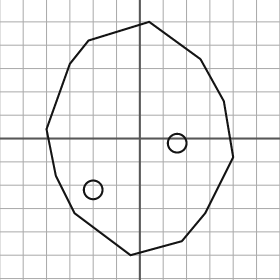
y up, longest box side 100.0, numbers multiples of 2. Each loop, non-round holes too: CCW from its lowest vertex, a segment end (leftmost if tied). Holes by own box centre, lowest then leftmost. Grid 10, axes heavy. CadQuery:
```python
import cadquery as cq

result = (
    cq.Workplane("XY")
    .moveTo(-4.0, -50.0)
    .lineTo(18.0, -44.0)
    .lineTo(28.0, -32.0)
    .lineTo(40.0, -8.0)
    .lineTo(36.0, 16.0)
    .lineTo(26.0, 34.0)
    .lineTo(4.0, 50.0)
    .lineTo(-22.0, 42.0)
    .lineTo(-30.0, 32.0)
    .lineTo(-40.0, 4.0)
    .lineTo(-36.0, -16.0)
    .lineTo(-28.0, -32.0)
    .close()
    .moveTo(-20.0, -22.0)
    .circle(4.0)
    .moveTo(16.0, -2.0)
    .circle(4.0)
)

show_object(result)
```